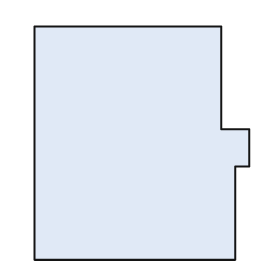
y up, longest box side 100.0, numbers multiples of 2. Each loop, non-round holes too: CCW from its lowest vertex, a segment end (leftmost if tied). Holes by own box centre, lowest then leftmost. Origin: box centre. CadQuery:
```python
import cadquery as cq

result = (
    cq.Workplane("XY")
    .moveTo(-46.0, -50.0)
    .lineTo(40.0, -50.0)
    .lineTo(40.0, -10.0)
    .lineTo(46.0, -10.0)
    .lineTo(46.0, 6.0)
    .lineTo(34.0, 6.0)
    .lineTo(34.0, 50.0)
    .lineTo(-46.0, 50.0)
    .close()
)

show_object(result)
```